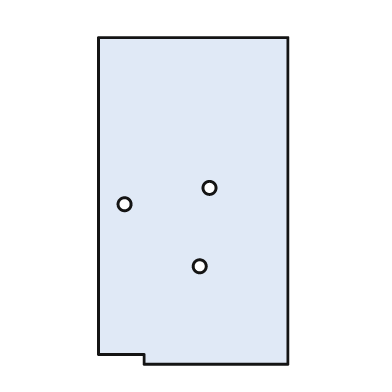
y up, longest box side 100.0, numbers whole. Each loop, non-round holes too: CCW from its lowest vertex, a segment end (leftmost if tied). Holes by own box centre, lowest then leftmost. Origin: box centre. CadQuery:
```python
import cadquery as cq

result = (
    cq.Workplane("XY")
    .moveTo(-15.0, -50.0)
    .lineTo(29.0, -50.0)
    .lineTo(29.0, 50.0)
    .lineTo(-29.0, 50.0)
    .lineTo(-29.0, -47.0)
    .lineTo(-15.0, -47.0)
    .close()
    .moveTo(2.0, -20.0)
    .circle(2.0)
    .moveTo(-21.0, -1.0)
    .circle(2.0)
    .moveTo(5.0, 4.0)
    .circle(2.0)
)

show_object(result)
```